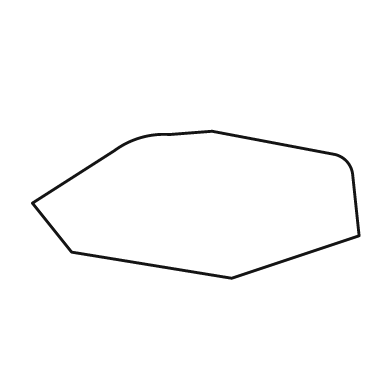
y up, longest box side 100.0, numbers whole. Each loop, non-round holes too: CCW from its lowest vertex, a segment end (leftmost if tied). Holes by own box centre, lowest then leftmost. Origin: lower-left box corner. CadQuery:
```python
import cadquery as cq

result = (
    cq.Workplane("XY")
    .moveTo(61.0, 0.0)
    .lineTo(100.0, 13.0)
    .lineTo(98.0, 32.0)
    .threePointArc((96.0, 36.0), (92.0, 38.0))
    .lineTo(55.0, 45.0)
    .lineTo(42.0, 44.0)
    .threePointArc((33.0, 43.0), (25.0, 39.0))
    .lineTo(0.0, 23.0)
    .lineTo(12.0, 8.0)
    .close()
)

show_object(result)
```